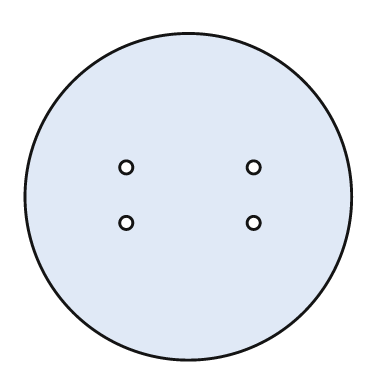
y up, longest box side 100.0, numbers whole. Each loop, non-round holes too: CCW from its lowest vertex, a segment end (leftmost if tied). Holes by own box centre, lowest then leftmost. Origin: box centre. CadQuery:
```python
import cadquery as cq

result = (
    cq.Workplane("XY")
    .moveTo(0.0, 0.0)
    .circle(50.0)
    .moveTo(-19.0, -8.0)
    .circle(2.0)
    .moveTo(20.0, -8.0)
    .circle(2.0)
    .moveTo(-19.0, 9.0)
    .circle(2.0)
    .moveTo(20.0, 9.0)
    .circle(2.0)
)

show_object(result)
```